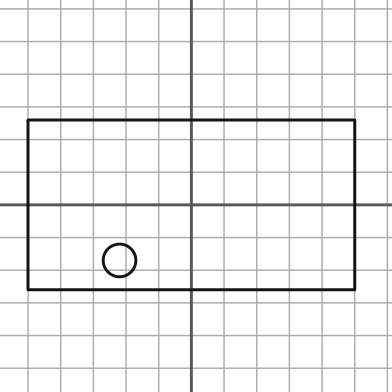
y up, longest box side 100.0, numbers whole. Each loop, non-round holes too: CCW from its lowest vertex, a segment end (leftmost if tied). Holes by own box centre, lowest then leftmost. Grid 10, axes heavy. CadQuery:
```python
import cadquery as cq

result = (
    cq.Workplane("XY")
    .moveTo(-50.0, -26.0)
    .lineTo(50.0, -26.0)
    .lineTo(50.0, 26.0)
    .lineTo(-50.0, 26.0)
    .close()
    .moveTo(-22.0, -17.0)
    .circle(5.0)
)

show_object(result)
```